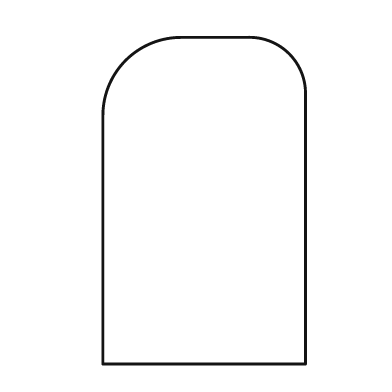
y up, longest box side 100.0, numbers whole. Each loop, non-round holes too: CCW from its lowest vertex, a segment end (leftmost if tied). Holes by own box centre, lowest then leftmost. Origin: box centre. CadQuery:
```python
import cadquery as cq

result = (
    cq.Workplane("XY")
    .moveTo(-31.0, -50.0)
    .lineTo(31.0, -50.0)
    .lineTo(31.0, 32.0)
    .threePointArc((26.0, 45.0), (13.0, 50.0))
    .lineTo(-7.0, 50.0)
    .threePointArc((-24.0, 43.0), (-31.0, 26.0))
    .close()
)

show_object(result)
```